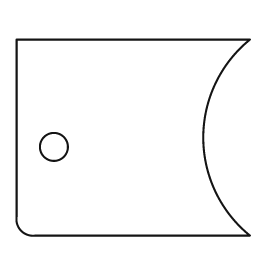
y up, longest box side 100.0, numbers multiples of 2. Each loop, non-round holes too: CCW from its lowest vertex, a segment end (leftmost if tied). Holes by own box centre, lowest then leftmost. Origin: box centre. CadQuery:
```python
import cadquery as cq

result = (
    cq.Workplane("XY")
    .moveTo(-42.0, -42.0)
    .lineTo(50.0, -42.0)
    .threePointArc((30.0, 0.0), (50.0, 42.0))
    .lineTo(-50.0, 42.0)
    .lineTo(-50.0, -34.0)
    .threePointArc((-48.0, -40.0), (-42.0, -42.0))
    .close()
    .moveTo(-34.0, -4.0)
    .circle(6.0)
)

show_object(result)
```